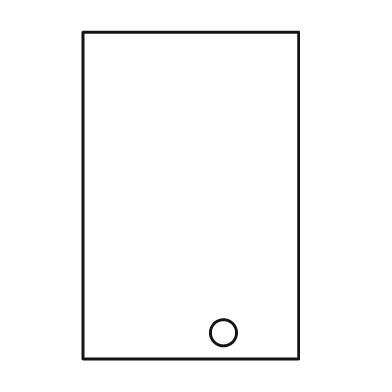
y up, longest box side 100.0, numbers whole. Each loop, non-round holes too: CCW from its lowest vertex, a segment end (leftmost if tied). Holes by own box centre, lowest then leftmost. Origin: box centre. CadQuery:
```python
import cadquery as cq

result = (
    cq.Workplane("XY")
    .moveTo(-33.0, -50.0)
    .lineTo(33.0, -50.0)
    .lineTo(33.0, 50.0)
    .lineTo(-33.0, 50.0)
    .close()
    .moveTo(10.0, -42.0)
    .circle(4.0)
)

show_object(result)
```